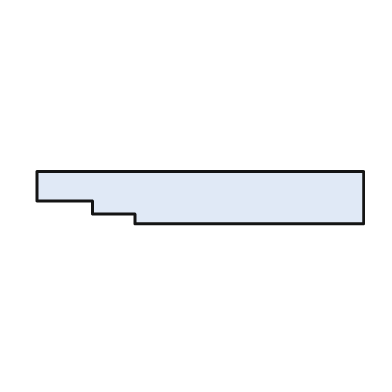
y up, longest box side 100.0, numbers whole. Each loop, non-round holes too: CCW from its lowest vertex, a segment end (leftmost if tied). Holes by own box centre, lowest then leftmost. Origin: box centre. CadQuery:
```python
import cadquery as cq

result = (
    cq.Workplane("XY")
    .moveTo(-20.0, -8.0)
    .lineTo(50.0, -8.0)
    .lineTo(50.0, 8.0)
    .lineTo(-50.0, 8.0)
    .lineTo(-50.0, -1.0)
    .lineTo(-33.0, -1.0)
    .lineTo(-33.0, -5.0)
    .lineTo(-20.0, -5.0)
    .close()
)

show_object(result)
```